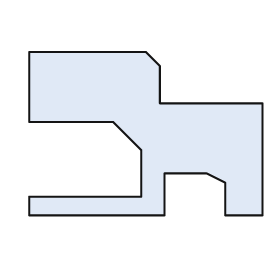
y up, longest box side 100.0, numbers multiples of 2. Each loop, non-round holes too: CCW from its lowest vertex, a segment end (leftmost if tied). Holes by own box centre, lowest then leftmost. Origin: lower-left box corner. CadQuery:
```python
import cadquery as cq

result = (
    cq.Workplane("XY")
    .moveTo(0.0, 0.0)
    .lineTo(58.0, 0.0)
    .lineTo(58.0, 18.0)
    .lineTo(76.0, 18.0)
    .lineTo(84.0, 14.0)
    .lineTo(84.0, 0.0)
    .lineTo(100.0, 0.0)
    .lineTo(100.0, 48.0)
    .lineTo(56.0, 48.0)
    .lineTo(56.0, 64.0)
    .lineTo(50.0, 70.0)
    .lineTo(0.0, 70.0)
    .lineTo(0.0, 40.0)
    .lineTo(36.0, 40.0)
    .lineTo(48.0, 28.0)
    .lineTo(48.0, 8.0)
    .lineTo(0.0, 8.0)
    .close()
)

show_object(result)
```